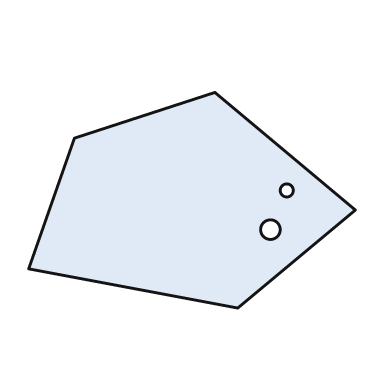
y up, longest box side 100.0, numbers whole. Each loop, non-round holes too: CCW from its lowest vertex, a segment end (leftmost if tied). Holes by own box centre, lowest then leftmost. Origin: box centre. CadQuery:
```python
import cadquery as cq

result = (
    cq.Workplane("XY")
    .moveTo(14.0, -33.0)
    .lineTo(50.0, -3.0)
    .lineTo(7.0, 33.0)
    .lineTo(-36.0, 19.0)
    .lineTo(-50.0, -21.0)
    .close()
    .moveTo(24.0, -9.0)
    .circle(3.0)
    .moveTo(29.0, 3.0)
    .circle(2.0)
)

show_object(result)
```